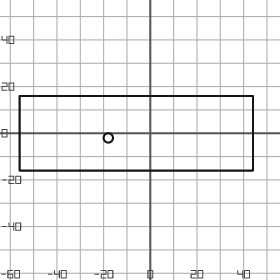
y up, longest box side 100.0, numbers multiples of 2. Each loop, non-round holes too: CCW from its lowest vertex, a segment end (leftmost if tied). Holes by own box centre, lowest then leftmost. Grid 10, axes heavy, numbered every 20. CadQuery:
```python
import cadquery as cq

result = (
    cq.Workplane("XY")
    .moveTo(-56.0, -16.0)
    .lineTo(44.0, -16.0)
    .lineTo(44.0, 16.0)
    .lineTo(-56.0, 16.0)
    .close()
    .moveTo(-18.0, -2.0)
    .circle(2.0)
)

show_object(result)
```